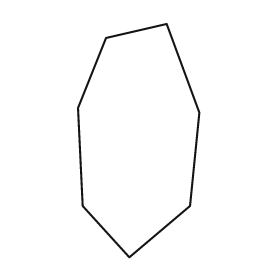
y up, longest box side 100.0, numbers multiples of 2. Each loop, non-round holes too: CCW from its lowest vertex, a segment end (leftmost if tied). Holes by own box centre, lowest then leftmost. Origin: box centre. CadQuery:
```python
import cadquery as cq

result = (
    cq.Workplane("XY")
    .moveTo(-4.0, -50.0)
    .lineTo(22.0, -28.0)
    .lineTo(26.0, 12.0)
    .lineTo(12.0, 50.0)
    .lineTo(-14.0, 44.0)
    .lineTo(-26.0, 14.0)
    .lineTo(-24.0, -28.0)
    .close()
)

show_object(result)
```